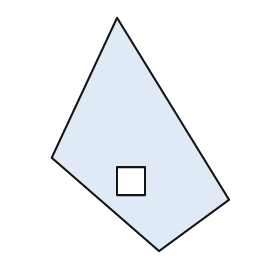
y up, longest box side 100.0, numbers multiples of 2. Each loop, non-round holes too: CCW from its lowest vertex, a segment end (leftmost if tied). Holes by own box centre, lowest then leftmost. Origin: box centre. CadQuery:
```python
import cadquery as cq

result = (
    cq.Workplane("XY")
    .moveTo(8.0, -50.0)
    .lineTo(38.0, -28.0)
    .lineTo(-10.0, 50.0)
    .lineTo(-38.0, -10.0)
    .close()
    .moveTo(-10.0, -26.0)
    .lineTo(2.0, -26.0)
    .lineTo(2.0, -14.0)
    .lineTo(-10.0, -14.0)
    .close()
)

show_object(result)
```